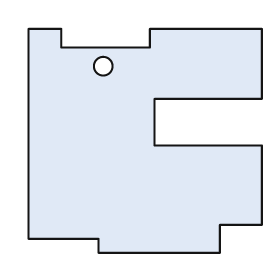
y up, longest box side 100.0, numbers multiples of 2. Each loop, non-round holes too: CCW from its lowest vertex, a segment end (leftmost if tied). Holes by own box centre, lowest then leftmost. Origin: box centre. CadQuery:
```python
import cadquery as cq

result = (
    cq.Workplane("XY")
    .moveTo(-20.0, -48.0)
    .lineTo(32.0, -48.0)
    .lineTo(32.0, -36.0)
    .lineTo(50.0, -36.0)
    .lineTo(50.0, -2.0)
    .lineTo(4.0, -2.0)
    .lineTo(4.0, 18.0)
    .lineTo(50.0, 18.0)
    .lineTo(50.0, 48.0)
    .lineTo(2.0, 48.0)
    .lineTo(2.0, 40.0)
    .lineTo(-36.0, 40.0)
    .lineTo(-36.0, 48.0)
    .lineTo(-50.0, 48.0)
    .lineTo(-50.0, -42.0)
    .lineTo(-20.0, -42.0)
    .close()
    .moveTo(-18.0, 32.0)
    .circle(4.0)
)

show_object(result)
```